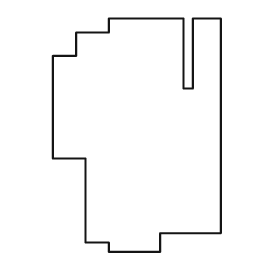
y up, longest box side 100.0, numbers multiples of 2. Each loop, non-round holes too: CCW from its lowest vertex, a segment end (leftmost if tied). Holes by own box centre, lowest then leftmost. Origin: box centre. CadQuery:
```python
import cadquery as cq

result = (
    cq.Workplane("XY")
    .moveTo(-12.0, -50.0)
    .lineTo(10.0, -50.0)
    .lineTo(10.0, -42.0)
    .lineTo(36.0, -42.0)
    .lineTo(36.0, 50.0)
    .lineTo(24.0, 50.0)
    .lineTo(24.0, 20.0)
    .lineTo(20.0, 20.0)
    .lineTo(20.0, 50.0)
    .lineTo(-12.0, 50.0)
    .lineTo(-12.0, 44.0)
    .lineTo(-26.0, 44.0)
    .lineTo(-26.0, 34.0)
    .lineTo(-36.0, 34.0)
    .lineTo(-36.0, -10.0)
    .lineTo(-22.0, -10.0)
    .lineTo(-22.0, -46.0)
    .lineTo(-12.0, -46.0)
    .close()
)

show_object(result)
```